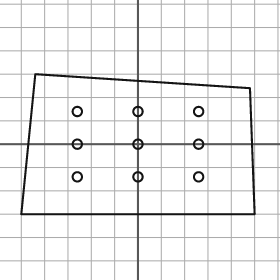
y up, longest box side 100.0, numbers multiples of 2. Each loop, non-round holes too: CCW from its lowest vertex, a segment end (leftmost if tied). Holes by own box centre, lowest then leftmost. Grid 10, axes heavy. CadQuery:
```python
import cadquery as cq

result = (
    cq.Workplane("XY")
    .moveTo(-50.0, -30.0)
    .lineTo(50.0, -30.0)
    .lineTo(48.0, 24.0)
    .lineTo(-44.0, 30.0)
    .close()
    .moveTo(-26.0, -14.0)
    .circle(2.0)
    .moveTo(0.0, -14.0)
    .circle(2.0)
    .moveTo(26.0, -14.0)
    .circle(2.0)
    .moveTo(-26.0, 0.0)
    .circle(2.0)
    .moveTo(0.0, 0.0)
    .circle(2.0)
    .moveTo(26.0, 0.0)
    .circle(2.0)
    .moveTo(-26.0, 14.0)
    .circle(2.0)
    .moveTo(0.0, 14.0)
    .circle(2.0)
    .moveTo(26.0, 14.0)
    .circle(2.0)
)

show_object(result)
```